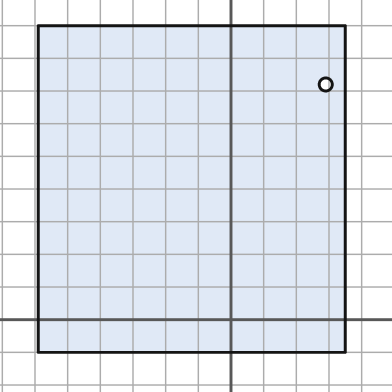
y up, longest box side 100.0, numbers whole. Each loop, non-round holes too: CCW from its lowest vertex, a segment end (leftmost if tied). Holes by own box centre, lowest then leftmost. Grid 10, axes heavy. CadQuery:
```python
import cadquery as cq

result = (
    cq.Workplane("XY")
    .moveTo(-59.0, -10.0)
    .lineTo(35.0, -10.0)
    .lineTo(35.0, 90.0)
    .lineTo(-59.0, 90.0)
    .close()
    .moveTo(29.0, 72.0)
    .circle(2.0)
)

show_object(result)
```